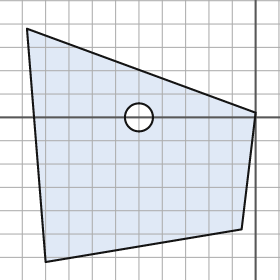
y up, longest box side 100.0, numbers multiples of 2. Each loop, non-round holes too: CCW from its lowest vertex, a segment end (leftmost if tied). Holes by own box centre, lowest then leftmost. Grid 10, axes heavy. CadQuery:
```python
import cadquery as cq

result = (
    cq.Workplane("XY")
    .moveTo(-90.0, -62.0)
    .lineTo(-6.0, -48.0)
    .lineTo(0.0, 2.0)
    .lineTo(-98.0, 38.0)
    .close()
    .moveTo(-50.0, 0.0)
    .circle(6.0)
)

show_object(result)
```